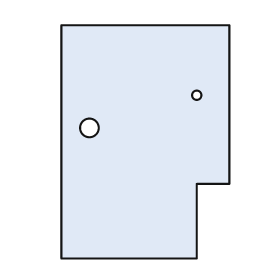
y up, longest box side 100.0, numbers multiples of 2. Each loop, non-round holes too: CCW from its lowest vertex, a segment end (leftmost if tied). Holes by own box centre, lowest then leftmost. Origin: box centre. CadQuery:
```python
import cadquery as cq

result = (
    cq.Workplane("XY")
    .moveTo(-36.0, -50.0)
    .lineTo(22.0, -50.0)
    .lineTo(22.0, -18.0)
    .lineTo(36.0, -18.0)
    .lineTo(36.0, 50.0)
    .lineTo(-36.0, 50.0)
    .close()
    .moveTo(-24.0, 6.0)
    .circle(4.0)
    .moveTo(22.0, 20.0)
    .circle(2.0)
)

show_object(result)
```